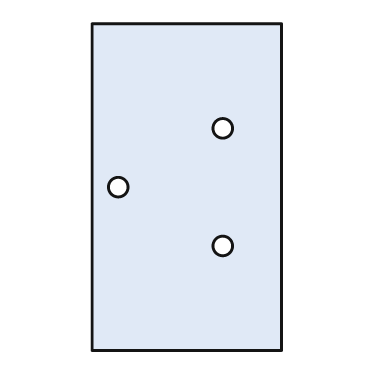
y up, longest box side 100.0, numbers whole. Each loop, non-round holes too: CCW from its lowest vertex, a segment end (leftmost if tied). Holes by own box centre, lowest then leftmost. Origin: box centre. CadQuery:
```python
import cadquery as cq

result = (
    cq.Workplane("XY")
    .moveTo(-29.0, -50.0)
    .lineTo(29.0, -50.0)
    .lineTo(29.0, 50.0)
    .lineTo(-29.0, 50.0)
    .close()
    .moveTo(11.0, -18.0)
    .circle(3.0)
    .moveTo(-21.0, 0.0)
    .circle(3.0)
    .moveTo(11.0, 18.0)
    .circle(3.0)
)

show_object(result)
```